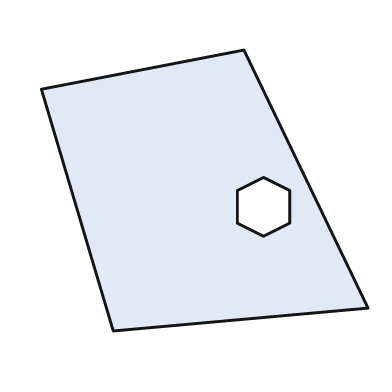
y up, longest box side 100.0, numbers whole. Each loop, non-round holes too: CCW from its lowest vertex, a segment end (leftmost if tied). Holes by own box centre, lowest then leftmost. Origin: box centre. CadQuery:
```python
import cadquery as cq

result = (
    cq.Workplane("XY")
    .moveTo(-28.0, -43.0)
    .lineTo(50.0, -36.0)
    .lineTo(12.0, 43.0)
    .lineTo(-50.0, 31.0)
    .close()
    .moveTo(18.0, -14.0)
    .lineTo(26.0, -10.0)
    .lineTo(26.0, 0.0)
    .lineTo(18.0, 4.0)
    .lineTo(10.0, 0.0)
    .lineTo(10.0, -10.0)
    .close()
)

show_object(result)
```